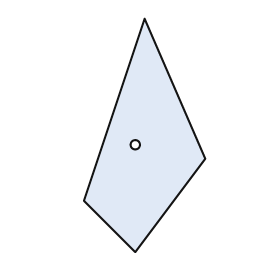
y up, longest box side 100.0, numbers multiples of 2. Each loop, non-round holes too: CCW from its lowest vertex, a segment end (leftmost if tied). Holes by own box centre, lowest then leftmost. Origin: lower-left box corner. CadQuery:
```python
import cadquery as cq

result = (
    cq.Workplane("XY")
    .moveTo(22.0, 0.0)
    .lineTo(52.0, 40.0)
    .lineTo(26.0, 100.0)
    .lineTo(0.0, 22.0)
    .close()
    .moveTo(22.0, 46.0)
    .circle(2.0)
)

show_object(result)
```